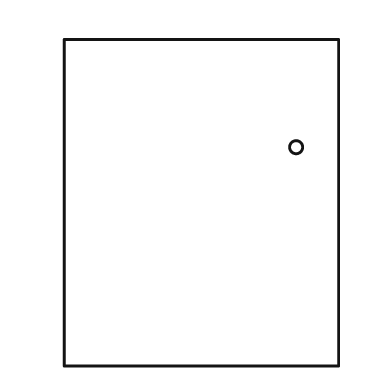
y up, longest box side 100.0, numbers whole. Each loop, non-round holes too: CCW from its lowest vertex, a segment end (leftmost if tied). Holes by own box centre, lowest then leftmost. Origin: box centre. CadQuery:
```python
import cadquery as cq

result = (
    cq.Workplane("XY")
    .moveTo(-42.0, -50.0)
    .lineTo(42.0, -50.0)
    .lineTo(42.0, 50.0)
    .lineTo(-42.0, 50.0)
    .close()
    .moveTo(29.0, 17.0)
    .circle(2.0)
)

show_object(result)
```